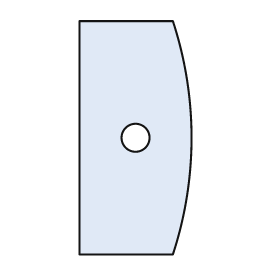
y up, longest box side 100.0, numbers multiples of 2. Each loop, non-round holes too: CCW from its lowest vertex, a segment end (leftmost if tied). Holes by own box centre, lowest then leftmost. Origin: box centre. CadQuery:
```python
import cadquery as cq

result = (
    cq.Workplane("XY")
    .moveTo(-24.0, -50.0)
    .lineTo(16.0, -50.0)
    .threePointArc((24.0, 0.0), (16.0, 50.0))
    .lineTo(-24.0, 50.0)
    .close()
    .moveTo(0.0, 0.0)
    .circle(6.0)
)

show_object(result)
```